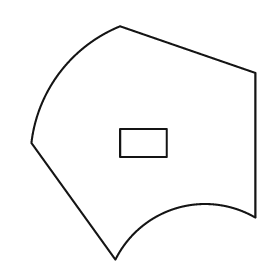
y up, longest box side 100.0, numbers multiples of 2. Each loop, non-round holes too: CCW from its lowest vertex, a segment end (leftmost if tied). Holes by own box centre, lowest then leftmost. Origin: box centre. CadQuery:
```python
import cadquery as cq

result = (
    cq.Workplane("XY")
    .moveTo(-12.0, -50.0)
    .threePointArc((14.0, -28.0), (48.0, -32.0))
    .lineTo(48.0, 30.0)
    .lineTo(-10.0, 50.0)
    .threePointArc((-36.0, 30.0), (-48.0, 0.0))
    .close()
    .moveTo(-10.0, -6.0)
    .lineTo(10.0, -6.0)
    .lineTo(10.0, 6.0)
    .lineTo(-10.0, 6.0)
    .close()
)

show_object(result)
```